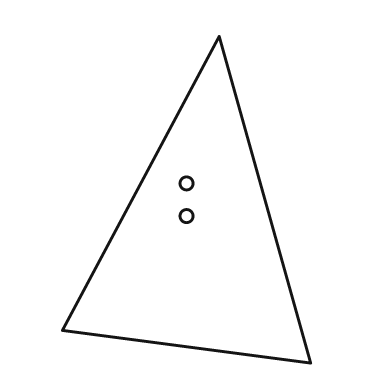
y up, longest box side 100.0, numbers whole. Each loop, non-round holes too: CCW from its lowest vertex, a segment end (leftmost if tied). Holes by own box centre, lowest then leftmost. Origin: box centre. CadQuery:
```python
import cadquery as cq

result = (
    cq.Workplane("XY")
    .moveTo(38.0, -50.0)
    .lineTo(10.0, 50.0)
    .lineTo(-38.0, -40.0)
    .close()
    .moveTo(0.0, -5.0)
    .circle(2.0)
    .moveTo(0.0, 5.0)
    .circle(2.0)
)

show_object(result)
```